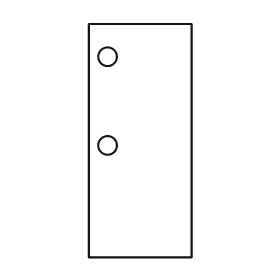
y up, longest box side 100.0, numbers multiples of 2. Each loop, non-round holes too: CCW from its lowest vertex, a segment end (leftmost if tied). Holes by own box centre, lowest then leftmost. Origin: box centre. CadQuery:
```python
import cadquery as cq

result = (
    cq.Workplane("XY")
    .moveTo(-22.0, -50.0)
    .lineTo(22.0, -50.0)
    .lineTo(22.0, 50.0)
    .lineTo(-22.0, 50.0)
    .close()
    .moveTo(-14.0, -2.0)
    .circle(4.0)
    .moveTo(-14.0, 36.0)
    .circle(4.0)
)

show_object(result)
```